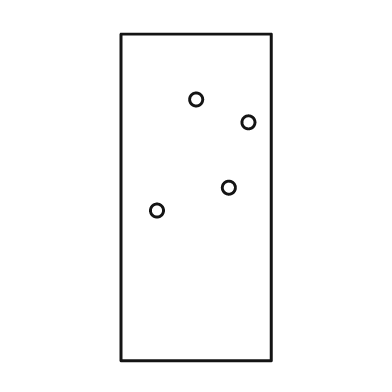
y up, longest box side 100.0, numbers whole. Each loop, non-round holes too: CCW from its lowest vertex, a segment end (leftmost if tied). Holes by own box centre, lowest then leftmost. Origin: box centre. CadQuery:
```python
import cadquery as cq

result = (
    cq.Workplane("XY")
    .moveTo(-23.0, -50.0)
    .lineTo(23.0, -50.0)
    .lineTo(23.0, 50.0)
    .lineTo(-23.0, 50.0)
    .close()
    .moveTo(-12.0, -4.0)
    .circle(2.0)
    .moveTo(10.0, 3.0)
    .circle(2.0)
    .moveTo(16.0, 23.0)
    .circle(2.0)
    .moveTo(0.0, 30.0)
    .circle(2.0)
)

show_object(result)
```